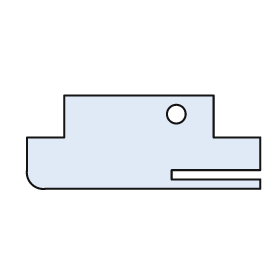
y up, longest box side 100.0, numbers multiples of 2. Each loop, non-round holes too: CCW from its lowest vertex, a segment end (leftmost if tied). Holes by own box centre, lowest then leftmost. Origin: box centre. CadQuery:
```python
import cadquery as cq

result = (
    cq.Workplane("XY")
    .moveTo(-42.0, -20.0)
    .lineTo(50.0, -20.0)
    .lineTo(50.0, -16.0)
    .lineTo(12.0, -16.0)
    .lineTo(12.0, -12.0)
    .lineTo(50.0, -12.0)
    .lineTo(50.0, 2.0)
    .lineTo(30.0, 2.0)
    .lineTo(30.0, 20.0)
    .lineTo(-34.0, 20.0)
    .lineTo(-34.0, 2.0)
    .lineTo(-50.0, 2.0)
    .lineTo(-50.0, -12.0)
    .threePointArc((-48.0, -18.0), (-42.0, -20.0))
    .close()
    .moveTo(14.0, 12.0)
    .circle(4.0)
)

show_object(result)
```